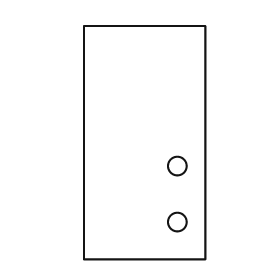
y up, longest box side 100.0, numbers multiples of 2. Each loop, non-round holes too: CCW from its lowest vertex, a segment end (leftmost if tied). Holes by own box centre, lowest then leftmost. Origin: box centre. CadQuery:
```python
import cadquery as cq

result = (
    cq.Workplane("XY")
    .moveTo(-26.0, -50.0)
    .lineTo(26.0, -50.0)
    .lineTo(26.0, 50.0)
    .lineTo(-26.0, 50.0)
    .close()
    .moveTo(14.0, -34.0)
    .circle(4.0)
    .moveTo(14.0, -10.0)
    .circle(4.0)
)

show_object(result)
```